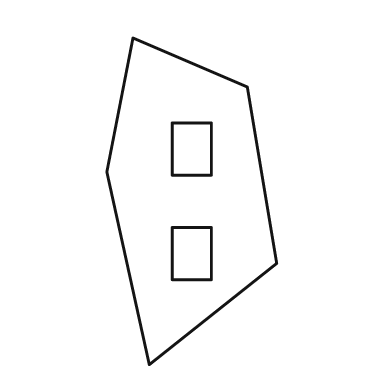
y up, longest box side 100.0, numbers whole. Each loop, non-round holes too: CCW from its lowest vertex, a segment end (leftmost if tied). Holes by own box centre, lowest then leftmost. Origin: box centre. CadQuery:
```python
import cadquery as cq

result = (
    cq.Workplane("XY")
    .moveTo(-13.0, -50.0)
    .lineTo(26.0, -19.0)
    .lineTo(17.0, 35.0)
    .lineTo(-18.0, 50.0)
    .lineTo(-26.0, 9.0)
    .close()
    .moveTo(-6.0, -24.0)
    .lineTo(6.0, -24.0)
    .lineTo(6.0, -8.0)
    .lineTo(-6.0, -8.0)
    .close()
    .moveTo(-6.0, 8.0)
    .lineTo(6.0, 8.0)
    .lineTo(6.0, 24.0)
    .lineTo(-6.0, 24.0)
    .close()
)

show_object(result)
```